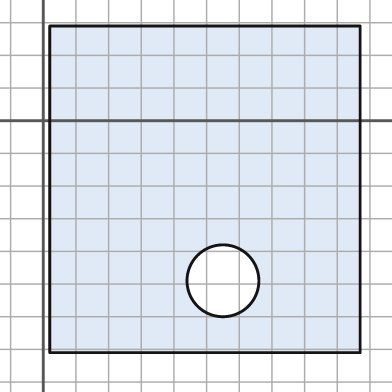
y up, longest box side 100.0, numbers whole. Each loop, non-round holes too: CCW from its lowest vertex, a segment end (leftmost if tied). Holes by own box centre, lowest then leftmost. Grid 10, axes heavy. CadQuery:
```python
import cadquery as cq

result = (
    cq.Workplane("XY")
    .moveTo(2.0, -71.0)
    .lineTo(97.0, -71.0)
    .lineTo(97.0, 29.0)
    .lineTo(2.0, 29.0)
    .close()
    .moveTo(55.0, -49.0)
    .circle(11.0)
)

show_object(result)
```